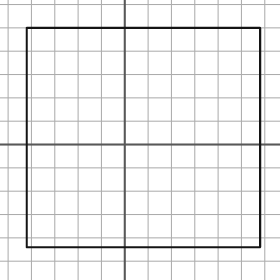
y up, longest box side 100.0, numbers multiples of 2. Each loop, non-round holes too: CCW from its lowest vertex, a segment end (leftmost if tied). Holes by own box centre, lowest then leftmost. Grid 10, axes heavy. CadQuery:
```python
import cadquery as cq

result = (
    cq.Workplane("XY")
    .moveTo(-42.0, -44.0)
    .lineTo(58.0, -44.0)
    .lineTo(58.0, 50.0)
    .lineTo(-42.0, 50.0)
    .close()
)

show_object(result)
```